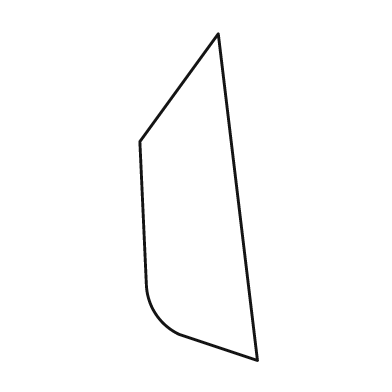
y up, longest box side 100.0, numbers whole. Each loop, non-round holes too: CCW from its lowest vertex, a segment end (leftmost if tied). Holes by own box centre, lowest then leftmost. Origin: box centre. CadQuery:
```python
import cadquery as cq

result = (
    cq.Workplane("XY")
    .moveTo(18.0, -50.0)
    .lineTo(6.0, 50.0)
    .lineTo(-18.0, 17.0)
    .lineTo(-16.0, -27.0)
    .threePointArc((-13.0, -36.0), (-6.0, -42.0))
    .close()
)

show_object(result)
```